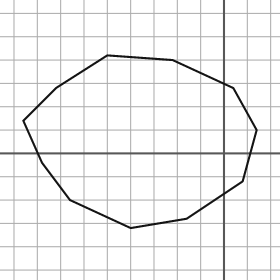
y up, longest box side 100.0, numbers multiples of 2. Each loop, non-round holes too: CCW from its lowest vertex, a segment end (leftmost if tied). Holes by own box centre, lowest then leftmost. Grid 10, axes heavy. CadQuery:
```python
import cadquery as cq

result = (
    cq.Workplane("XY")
    .moveTo(-40.0, -32.0)
    .lineTo(-16.0, -28.0)
    .lineTo(8.0, -12.0)
    .lineTo(14.0, 10.0)
    .lineTo(4.0, 28.0)
    .lineTo(-22.0, 40.0)
    .lineTo(-50.0, 42.0)
    .lineTo(-72.0, 28.0)
    .lineTo(-86.0, 14.0)
    .lineTo(-78.0, -4.0)
    .lineTo(-66.0, -20.0)
    .close()
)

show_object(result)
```